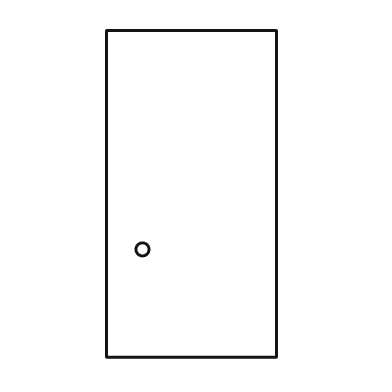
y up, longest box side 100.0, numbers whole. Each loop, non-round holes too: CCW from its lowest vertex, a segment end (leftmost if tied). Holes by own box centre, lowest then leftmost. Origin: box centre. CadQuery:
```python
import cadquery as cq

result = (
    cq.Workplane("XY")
    .moveTo(-26.0, -50.0)
    .lineTo(26.0, -50.0)
    .lineTo(26.0, 50.0)
    .lineTo(-26.0, 50.0)
    .close()
    .moveTo(-15.0, -17.0)
    .circle(2.0)
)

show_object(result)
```